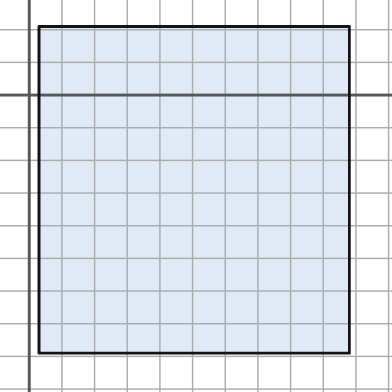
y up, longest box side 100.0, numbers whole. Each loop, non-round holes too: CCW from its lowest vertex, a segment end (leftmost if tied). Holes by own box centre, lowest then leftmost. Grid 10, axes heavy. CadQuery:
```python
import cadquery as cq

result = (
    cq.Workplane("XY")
    .moveTo(3.0, -79.0)
    .lineTo(98.0, -79.0)
    .lineTo(98.0, 21.0)
    .lineTo(3.0, 21.0)
    .close()
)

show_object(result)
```